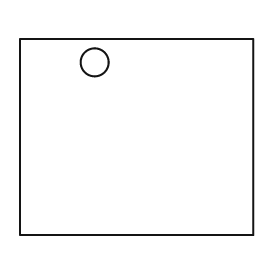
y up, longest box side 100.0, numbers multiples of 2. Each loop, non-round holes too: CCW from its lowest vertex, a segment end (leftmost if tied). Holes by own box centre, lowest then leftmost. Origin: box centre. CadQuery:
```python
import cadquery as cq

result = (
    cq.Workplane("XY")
    .moveTo(-50.0, -42.0)
    .lineTo(50.0, -42.0)
    .lineTo(50.0, 42.0)
    .lineTo(-50.0, 42.0)
    .close()
    .moveTo(-18.0, 32.0)
    .circle(6.0)
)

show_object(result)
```